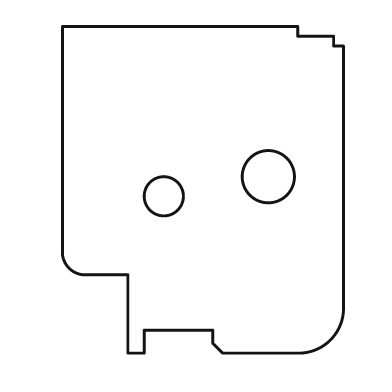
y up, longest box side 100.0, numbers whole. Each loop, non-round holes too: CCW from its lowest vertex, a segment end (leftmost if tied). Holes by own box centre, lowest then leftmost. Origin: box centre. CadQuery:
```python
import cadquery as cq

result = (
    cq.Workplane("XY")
    .moveTo(-23.0, -50.0)
    .lineTo(-18.0, -50.0)
    .lineTo(-18.0, -43.0)
    .lineTo(3.0, -43.0)
    .lineTo(3.0, -47.0)
    .lineTo(6.0, -50.0)
    .lineTo(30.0, -50.0)
    .threePointArc((39.0, -46.0), (43.0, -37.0))
    .lineTo(43.0, 44.0)
    .lineTo(40.0, 44.0)
    .lineTo(40.0, 47.0)
    .lineTo(29.0, 47.0)
    .lineTo(29.0, 50.0)
    .lineTo(-43.0, 50.0)
    .lineTo(-43.0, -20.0)
    .threePointArc((-41.0, -24.0), (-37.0, -26.0))
    .lineTo(-23.0, -26.0)
    .close()
    .moveTo(-12.0, -2.0)
    .circle(6.0)
    .moveTo(20.0, 4.0)
    .circle(8.0)
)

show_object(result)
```